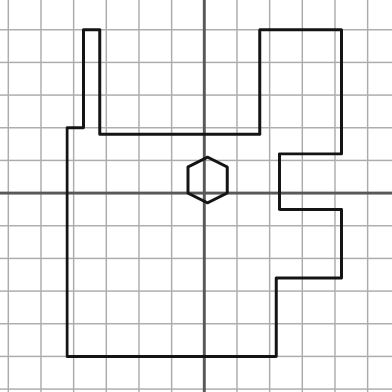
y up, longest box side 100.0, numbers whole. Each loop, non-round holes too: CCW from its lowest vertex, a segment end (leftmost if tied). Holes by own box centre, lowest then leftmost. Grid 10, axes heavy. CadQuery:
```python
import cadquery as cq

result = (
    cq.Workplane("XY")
    .moveTo(-42.0, -50.0)
    .lineTo(22.0, -50.0)
    .lineTo(22.0, -26.0)
    .lineTo(42.0, -26.0)
    .lineTo(42.0, -5.0)
    .lineTo(23.0, -5.0)
    .lineTo(23.0, 12.0)
    .lineTo(42.0, 12.0)
    .lineTo(42.0, 50.0)
    .lineTo(17.0, 50.0)
    .lineTo(17.0, 18.0)
    .lineTo(-32.0, 18.0)
    .lineTo(-32.0, 50.0)
    .lineTo(-37.0, 50.0)
    .lineTo(-37.0, 20.0)
    .lineTo(-42.0, 20.0)
    .close()
    .moveTo(1.0, -3.0)
    .lineTo(7.0, 0.0)
    .lineTo(7.0, 8.0)
    .lineTo(1.0, 11.0)
    .lineTo(-5.0, 8.0)
    .lineTo(-5.0, 0.0)
    .close()
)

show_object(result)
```